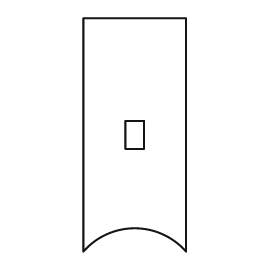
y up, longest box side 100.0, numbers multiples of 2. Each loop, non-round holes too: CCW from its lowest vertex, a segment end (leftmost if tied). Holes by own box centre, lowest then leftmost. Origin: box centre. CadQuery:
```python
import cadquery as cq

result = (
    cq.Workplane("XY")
    .moveTo(-22.0, -50.0)
    .threePointArc((0.0, -40.0), (22.0, -50.0))
    .lineTo(22.0, 50.0)
    .lineTo(-22.0, 50.0)
    .close()
    .moveTo(-4.0, -6.0)
    .lineTo(4.0, -6.0)
    .lineTo(4.0, 6.0)
    .lineTo(-4.0, 6.0)
    .close()
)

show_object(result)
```